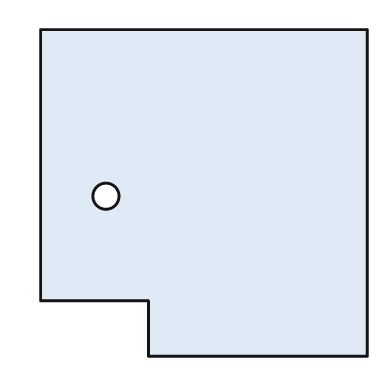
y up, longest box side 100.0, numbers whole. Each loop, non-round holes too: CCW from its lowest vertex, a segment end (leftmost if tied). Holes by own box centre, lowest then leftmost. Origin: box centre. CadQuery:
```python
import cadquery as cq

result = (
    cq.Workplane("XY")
    .moveTo(-17.0, -50.0)
    .lineTo(50.0, -50.0)
    .lineTo(50.0, 50.0)
    .lineTo(-50.0, 50.0)
    .lineTo(-50.0, -33.0)
    .lineTo(-17.0, -33.0)
    .close()
    .moveTo(-30.0, -1.0)
    .circle(4.0)
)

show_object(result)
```